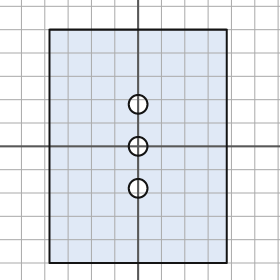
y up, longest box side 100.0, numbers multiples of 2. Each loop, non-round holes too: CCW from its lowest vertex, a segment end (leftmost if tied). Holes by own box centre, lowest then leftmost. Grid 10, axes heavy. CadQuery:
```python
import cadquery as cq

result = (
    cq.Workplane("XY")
    .moveTo(-38.0, -50.0)
    .lineTo(38.0, -50.0)
    .lineTo(38.0, 50.0)
    .lineTo(-38.0, 50.0)
    .close()
    .moveTo(0.0, -18.0)
    .circle(4.0)
    .moveTo(0.0, 0.0)
    .circle(4.0)
    .moveTo(0.0, 18.0)
    .circle(4.0)
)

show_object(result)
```